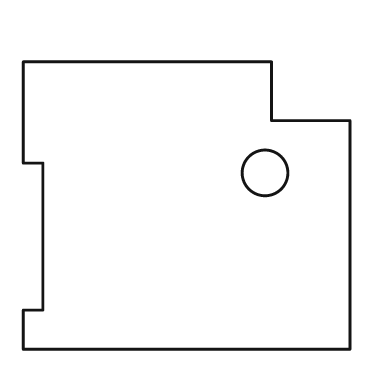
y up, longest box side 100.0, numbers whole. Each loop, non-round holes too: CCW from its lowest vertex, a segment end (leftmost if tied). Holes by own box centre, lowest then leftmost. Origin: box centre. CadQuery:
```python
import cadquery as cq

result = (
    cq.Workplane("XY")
    .moveTo(-50.0, -44.0)
    .lineTo(50.0, -44.0)
    .lineTo(50.0, 26.0)
    .lineTo(26.0, 26.0)
    .lineTo(26.0, 44.0)
    .lineTo(-50.0, 44.0)
    .lineTo(-50.0, 13.0)
    .lineTo(-44.0, 13.0)
    .lineTo(-44.0, -32.0)
    .lineTo(-50.0, -32.0)
    .close()
    .moveTo(24.0, 10.0)
    .circle(7.0)
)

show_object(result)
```